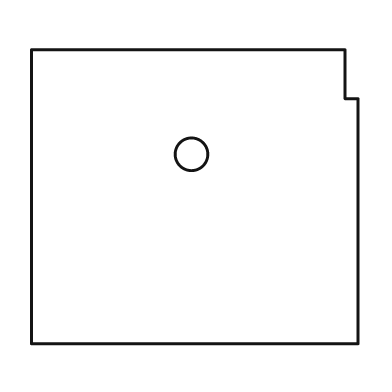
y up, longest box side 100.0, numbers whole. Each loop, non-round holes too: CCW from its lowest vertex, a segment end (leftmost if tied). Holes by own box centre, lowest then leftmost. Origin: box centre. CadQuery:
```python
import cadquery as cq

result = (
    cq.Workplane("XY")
    .moveTo(-50.0, -45.0)
    .lineTo(50.0, -45.0)
    .lineTo(50.0, 30.0)
    .lineTo(46.0, 30.0)
    .lineTo(46.0, 45.0)
    .lineTo(-50.0, 45.0)
    .close()
    .moveTo(-1.0, 13.0)
    .circle(5.0)
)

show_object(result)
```